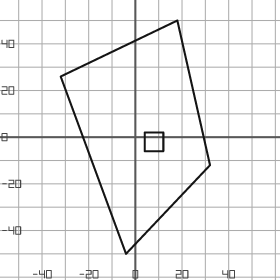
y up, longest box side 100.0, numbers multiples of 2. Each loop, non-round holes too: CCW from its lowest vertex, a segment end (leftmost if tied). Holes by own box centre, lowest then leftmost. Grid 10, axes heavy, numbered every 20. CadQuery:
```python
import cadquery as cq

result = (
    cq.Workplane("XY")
    .moveTo(-4.0, -50.0)
    .lineTo(32.0, -12.0)
    .lineTo(18.0, 50.0)
    .lineTo(-32.0, 26.0)
    .close()
    .moveTo(4.0, -6.0)
    .lineTo(12.0, -6.0)
    .lineTo(12.0, 2.0)
    .lineTo(4.0, 2.0)
    .close()
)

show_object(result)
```